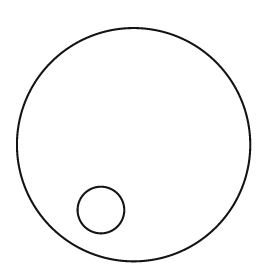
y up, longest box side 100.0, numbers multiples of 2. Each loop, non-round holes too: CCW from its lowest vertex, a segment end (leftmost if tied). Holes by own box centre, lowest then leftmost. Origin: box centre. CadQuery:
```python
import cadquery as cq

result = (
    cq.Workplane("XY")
    .moveTo(0.0, 0.0)
    .circle(50.0)
    .moveTo(-14.0, -28.0)
    .circle(10.0)
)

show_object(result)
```